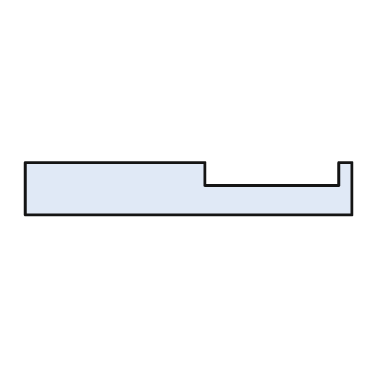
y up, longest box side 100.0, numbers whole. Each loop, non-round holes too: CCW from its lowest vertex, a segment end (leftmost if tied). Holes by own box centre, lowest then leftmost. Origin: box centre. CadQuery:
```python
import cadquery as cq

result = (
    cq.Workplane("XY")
    .moveTo(-50.0, -8.0)
    .lineTo(50.0, -8.0)
    .lineTo(50.0, 8.0)
    .lineTo(46.0, 8.0)
    .lineTo(46.0, 1.0)
    .lineTo(5.0, 1.0)
    .lineTo(5.0, 8.0)
    .lineTo(-50.0, 8.0)
    .close()
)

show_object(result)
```